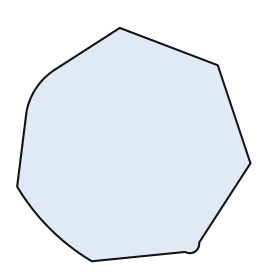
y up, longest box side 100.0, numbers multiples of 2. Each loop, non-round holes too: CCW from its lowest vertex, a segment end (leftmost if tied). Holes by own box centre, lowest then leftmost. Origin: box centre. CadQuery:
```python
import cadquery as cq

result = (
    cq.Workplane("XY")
    .moveTo(-18.0, -50.0)
    .lineTo(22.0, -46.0)
    .threePointArc((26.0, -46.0), (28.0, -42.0))
    .lineTo(50.0, -8.0)
    .lineTo(36.0, 34.0)
    .lineTo(-6.0, 50.0)
    .lineTo(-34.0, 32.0)
    .threePointArc((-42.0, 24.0), (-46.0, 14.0))
    .lineTo(-50.0, -18.0)
    .threePointArc((-36.0, -36.0), (-18.0, -50.0))
    .close()
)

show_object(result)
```